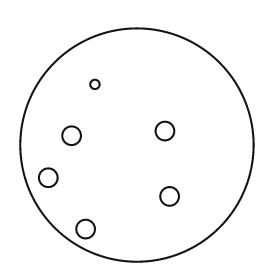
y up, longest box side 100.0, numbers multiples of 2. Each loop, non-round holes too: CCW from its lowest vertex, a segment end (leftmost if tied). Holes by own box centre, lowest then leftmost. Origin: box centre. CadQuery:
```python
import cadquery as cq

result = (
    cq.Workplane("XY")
    .moveTo(0.0, 0.0)
    .circle(50.0)
    .moveTo(-22.0, -36.0)
    .circle(4.0)
    .moveTo(14.0, -22.0)
    .circle(4.0)
    .moveTo(-38.0, -14.0)
    .circle(4.0)
    .moveTo(-28.0, 4.0)
    .circle(4.0)
    .moveTo(12.0, 6.0)
    .circle(4.0)
    .moveTo(-18.0, 26.0)
    .circle(2.0)
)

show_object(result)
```